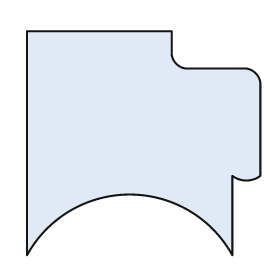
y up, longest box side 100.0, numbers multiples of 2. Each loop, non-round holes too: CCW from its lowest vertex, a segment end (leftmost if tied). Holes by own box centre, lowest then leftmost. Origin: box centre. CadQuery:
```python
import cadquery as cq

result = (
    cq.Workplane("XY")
    .moveTo(-50.0, -48.0)
    .threePointArc((-6.0, -22.0), (38.0, -48.0))
    .lineTo(38.0, -14.0)
    .threePointArc((44.0, -16.0), (50.0, -14.0))
    .lineTo(50.0, 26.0)
    .threePointArc((48.0, 30.0), (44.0, 32.0))
    .lineTo(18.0, 32.0)
    .threePointArc((14.0, 34.0), (12.0, 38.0))
    .lineTo(12.0, 48.0)
    .lineTo(-50.0, 48.0)
    .close()
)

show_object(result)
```